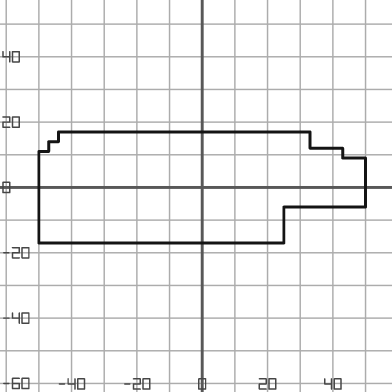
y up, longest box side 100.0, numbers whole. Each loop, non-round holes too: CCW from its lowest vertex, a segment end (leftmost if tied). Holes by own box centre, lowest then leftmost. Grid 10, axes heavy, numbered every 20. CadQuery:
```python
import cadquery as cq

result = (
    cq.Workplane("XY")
    .moveTo(-50.0, -17.0)
    .lineTo(25.0, -17.0)
    .lineTo(25.0, -6.0)
    .lineTo(50.0, -6.0)
    .lineTo(50.0, 9.0)
    .lineTo(43.0, 9.0)
    .lineTo(43.0, 12.0)
    .lineTo(33.0, 12.0)
    .lineTo(33.0, 17.0)
    .lineTo(-44.0, 17.0)
    .lineTo(-44.0, 14.0)
    .lineTo(-47.0, 14.0)
    .lineTo(-47.0, 11.0)
    .lineTo(-50.0, 11.0)
    .close()
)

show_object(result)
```